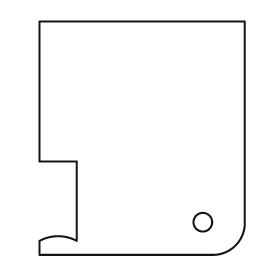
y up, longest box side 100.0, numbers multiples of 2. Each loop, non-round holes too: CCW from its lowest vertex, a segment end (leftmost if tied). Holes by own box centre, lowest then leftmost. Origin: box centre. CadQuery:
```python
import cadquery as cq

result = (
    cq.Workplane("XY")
    .moveTo(-44.0, -50.0)
    .lineTo(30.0, -50.0)
    .threePointArc((40.0, -46.0), (44.0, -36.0))
    .lineTo(44.0, 50.0)
    .lineTo(-44.0, 50.0)
    .lineTo(-44.0, -10.0)
    .lineTo(-28.0, -10.0)
    .lineTo(-28.0, -44.0)
    .threePointArc((-36.0, -42.0), (-44.0, -44.0))
    .close()
    .moveTo(26.0, -36.0)
    .circle(4.0)
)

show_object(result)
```